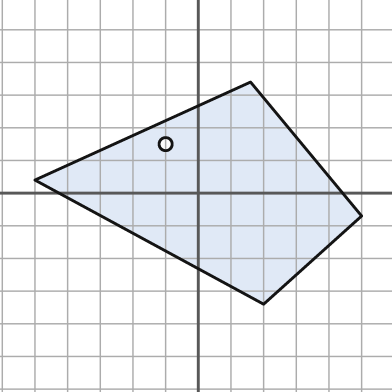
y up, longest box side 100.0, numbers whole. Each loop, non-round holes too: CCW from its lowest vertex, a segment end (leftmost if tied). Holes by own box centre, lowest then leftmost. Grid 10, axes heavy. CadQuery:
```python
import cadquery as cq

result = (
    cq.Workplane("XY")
    .moveTo(20.0, -34.0)
    .lineTo(50.0, -7.0)
    .lineTo(16.0, 34.0)
    .lineTo(-50.0, 4.0)
    .close()
    .moveTo(-10.0, 15.0)
    .circle(2.0)
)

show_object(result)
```